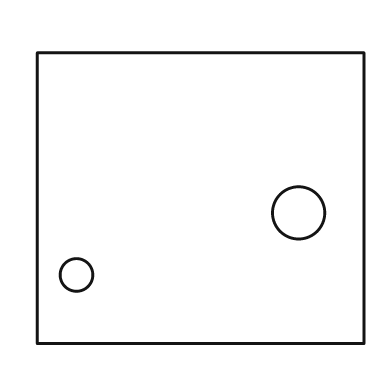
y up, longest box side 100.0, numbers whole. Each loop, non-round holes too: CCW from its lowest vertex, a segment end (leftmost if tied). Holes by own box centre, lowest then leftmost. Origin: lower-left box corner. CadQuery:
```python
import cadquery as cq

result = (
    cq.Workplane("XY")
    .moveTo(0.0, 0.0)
    .lineTo(100.0, 0.0)
    .lineTo(100.0, 89.0)
    .lineTo(0.0, 89.0)
    .close()
    .moveTo(12.0, 21.0)
    .circle(5.0)
    .moveTo(80.0, 40.0)
    .circle(8.0)
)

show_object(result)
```